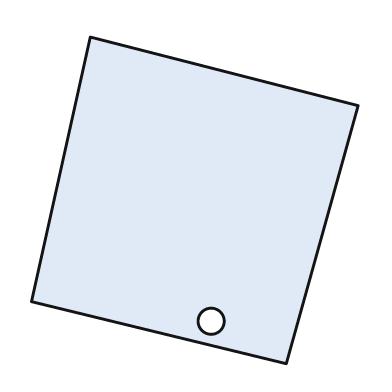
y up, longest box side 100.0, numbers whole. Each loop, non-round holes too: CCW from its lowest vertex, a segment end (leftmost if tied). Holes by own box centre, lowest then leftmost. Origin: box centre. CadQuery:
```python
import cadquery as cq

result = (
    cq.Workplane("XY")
    .moveTo(28.0, -50.0)
    .lineTo(50.0, 29.0)
    .lineTo(-32.0, 50.0)
    .lineTo(-50.0, -31.0)
    .close()
    .moveTo(5.0, -37.0)
    .circle(4.0)
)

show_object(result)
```